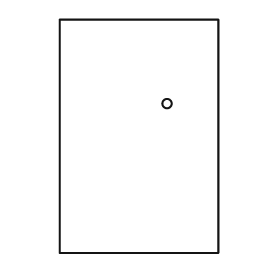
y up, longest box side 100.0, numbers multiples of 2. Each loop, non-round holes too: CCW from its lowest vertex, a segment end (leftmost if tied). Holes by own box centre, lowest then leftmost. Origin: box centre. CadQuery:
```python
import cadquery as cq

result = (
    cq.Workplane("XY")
    .moveTo(-34.0, -50.0)
    .lineTo(34.0, -50.0)
    .lineTo(34.0, 50.0)
    .lineTo(-34.0, 50.0)
    .close()
    .moveTo(12.0, 14.0)
    .circle(2.0)
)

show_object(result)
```